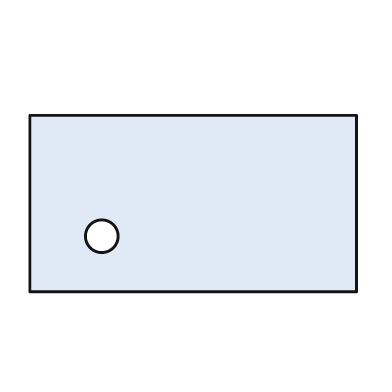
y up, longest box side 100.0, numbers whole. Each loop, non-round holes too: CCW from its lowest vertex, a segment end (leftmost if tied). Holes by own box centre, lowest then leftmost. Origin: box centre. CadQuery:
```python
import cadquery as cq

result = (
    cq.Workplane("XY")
    .moveTo(-50.0, -27.0)
    .lineTo(50.0, -27.0)
    .lineTo(50.0, 27.0)
    .lineTo(-50.0, 27.0)
    .close()
    .moveTo(-28.0, -10.0)
    .circle(5.0)
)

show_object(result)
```